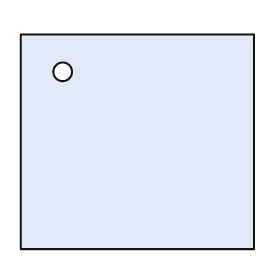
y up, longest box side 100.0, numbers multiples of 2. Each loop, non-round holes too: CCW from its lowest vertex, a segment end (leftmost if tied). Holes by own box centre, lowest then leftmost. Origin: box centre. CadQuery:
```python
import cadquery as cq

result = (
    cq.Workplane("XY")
    .moveTo(-50.0, -46.0)
    .lineTo(50.0, -46.0)
    .lineTo(50.0, 46.0)
    .lineTo(-50.0, 46.0)
    .close()
    .moveTo(-32.0, 30.0)
    .circle(4.0)
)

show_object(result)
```